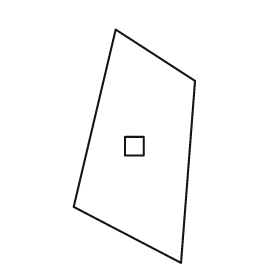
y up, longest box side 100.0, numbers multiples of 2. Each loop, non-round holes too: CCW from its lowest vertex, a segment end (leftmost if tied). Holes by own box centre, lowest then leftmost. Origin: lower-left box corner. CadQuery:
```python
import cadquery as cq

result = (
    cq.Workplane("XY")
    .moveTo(46.0, 0.0)
    .lineTo(52.0, 78.0)
    .lineTo(18.0, 100.0)
    .lineTo(0.0, 24.0)
    .close()
    .moveTo(22.0, 46.0)
    .lineTo(30.0, 46.0)
    .lineTo(30.0, 54.0)
    .lineTo(22.0, 54.0)
    .close()
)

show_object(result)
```